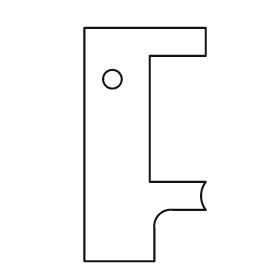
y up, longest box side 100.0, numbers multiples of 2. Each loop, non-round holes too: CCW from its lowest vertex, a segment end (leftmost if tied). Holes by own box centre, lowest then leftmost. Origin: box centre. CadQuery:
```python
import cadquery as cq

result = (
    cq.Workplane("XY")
    .moveTo(-26.0, -50.0)
    .lineTo(4.0, -50.0)
    .lineTo(4.0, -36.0)
    .threePointArc((6.0, -30.0), (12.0, -28.0))
    .lineTo(26.0, -28.0)
    .threePointArc((24.0, -22.0), (26.0, -16.0))
    .lineTo(2.0, -16.0)
    .lineTo(2.0, 38.0)
    .lineTo(26.0, 38.0)
    .lineTo(26.0, 50.0)
    .lineTo(-26.0, 50.0)
    .close()
    .moveTo(-14.0, 28.0)
    .circle(4.0)
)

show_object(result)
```